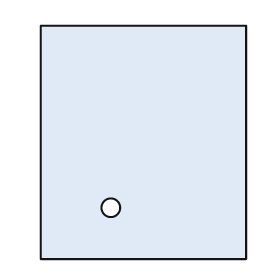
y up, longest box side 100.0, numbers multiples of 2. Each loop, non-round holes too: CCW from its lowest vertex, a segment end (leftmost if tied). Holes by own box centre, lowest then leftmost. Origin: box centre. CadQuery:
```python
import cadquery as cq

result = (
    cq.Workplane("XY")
    .moveTo(-44.0, -50.0)
    .lineTo(44.0, -50.0)
    .lineTo(44.0, 50.0)
    .lineTo(-44.0, 50.0)
    .close()
    .moveTo(-14.0, -28.0)
    .circle(4.0)
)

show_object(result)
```